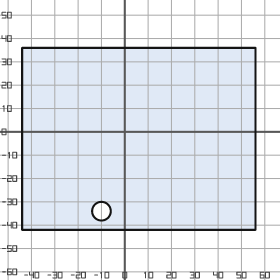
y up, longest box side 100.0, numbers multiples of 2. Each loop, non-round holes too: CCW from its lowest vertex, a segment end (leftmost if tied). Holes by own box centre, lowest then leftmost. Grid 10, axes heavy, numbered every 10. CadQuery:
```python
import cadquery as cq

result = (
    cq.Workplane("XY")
    .moveTo(-44.0, -42.0)
    .lineTo(56.0, -42.0)
    .lineTo(56.0, 36.0)
    .lineTo(-44.0, 36.0)
    .close()
    .moveTo(-10.0, -34.0)
    .circle(4.0)
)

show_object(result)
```